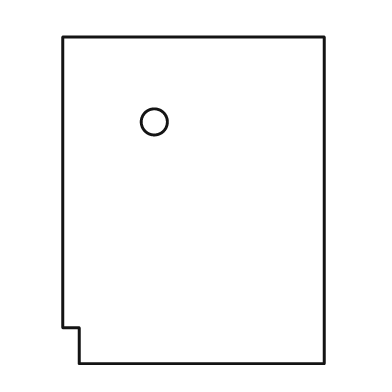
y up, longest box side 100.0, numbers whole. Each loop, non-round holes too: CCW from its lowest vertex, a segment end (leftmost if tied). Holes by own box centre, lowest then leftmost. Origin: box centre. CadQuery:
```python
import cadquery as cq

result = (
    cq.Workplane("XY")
    .moveTo(-35.0, -50.0)
    .lineTo(40.0, -50.0)
    .lineTo(40.0, 50.0)
    .lineTo(-40.0, 50.0)
    .lineTo(-40.0, -39.0)
    .lineTo(-35.0, -39.0)
    .close()
    .moveTo(-12.0, 24.0)
    .circle(4.0)
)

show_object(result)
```